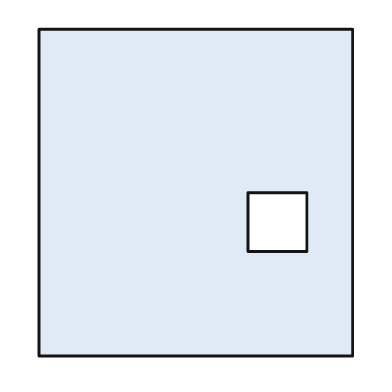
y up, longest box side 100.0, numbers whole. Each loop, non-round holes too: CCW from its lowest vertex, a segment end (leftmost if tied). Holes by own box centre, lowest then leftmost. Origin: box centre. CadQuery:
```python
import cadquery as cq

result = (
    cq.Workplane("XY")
    .moveTo(-48.0, -50.0)
    .lineTo(48.0, -50.0)
    .lineTo(48.0, 50.0)
    .lineTo(-48.0, 50.0)
    .close()
    .moveTo(16.0, -18.0)
    .lineTo(34.0, -18.0)
    .lineTo(34.0, 0.0)
    .lineTo(16.0, 0.0)
    .close()
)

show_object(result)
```